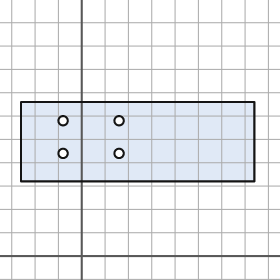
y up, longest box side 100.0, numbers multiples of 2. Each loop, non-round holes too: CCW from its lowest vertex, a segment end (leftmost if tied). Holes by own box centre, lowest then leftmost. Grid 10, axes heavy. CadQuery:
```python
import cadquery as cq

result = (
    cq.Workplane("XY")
    .moveTo(-26.0, 32.0)
    .lineTo(74.0, 32.0)
    .lineTo(74.0, 66.0)
    .lineTo(-26.0, 66.0)
    .close()
    .moveTo(-8.0, 44.0)
    .circle(2.0)
    .moveTo(16.0, 44.0)
    .circle(2.0)
    .moveTo(-8.0, 58.0)
    .circle(2.0)
    .moveTo(16.0, 58.0)
    .circle(2.0)
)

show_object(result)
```